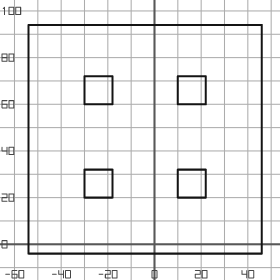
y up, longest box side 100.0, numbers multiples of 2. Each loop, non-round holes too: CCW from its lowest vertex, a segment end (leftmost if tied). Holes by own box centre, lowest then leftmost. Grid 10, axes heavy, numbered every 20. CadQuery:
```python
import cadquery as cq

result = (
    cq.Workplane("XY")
    .moveTo(-54.0, -4.0)
    .lineTo(46.0, -4.0)
    .lineTo(46.0, 94.0)
    .lineTo(-54.0, 94.0)
    .close()
    .moveTo(-30.0, 20.0)
    .lineTo(-18.0, 20.0)
    .lineTo(-18.0, 32.0)
    .lineTo(-30.0, 32.0)
    .close()
    .moveTo(10.0, 20.0)
    .lineTo(22.0, 20.0)
    .lineTo(22.0, 32.0)
    .lineTo(10.0, 32.0)
    .close()
    .moveTo(-30.0, 60.0)
    .lineTo(-18.0, 60.0)
    .lineTo(-18.0, 72.0)
    .lineTo(-30.0, 72.0)
    .close()
    .moveTo(10.0, 60.0)
    .lineTo(22.0, 60.0)
    .lineTo(22.0, 72.0)
    .lineTo(10.0, 72.0)
    .close()
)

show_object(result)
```